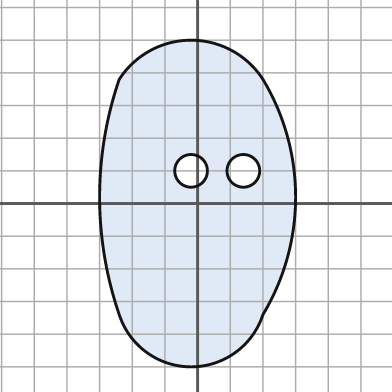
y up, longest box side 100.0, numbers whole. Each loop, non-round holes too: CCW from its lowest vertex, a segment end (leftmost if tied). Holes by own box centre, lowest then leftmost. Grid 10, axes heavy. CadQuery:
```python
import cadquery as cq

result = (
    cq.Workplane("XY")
    .moveTo(-24.0, -34.0)
    .threePointArc((-2.0, -50.0), (20.0, -34.0))
    .threePointArc((30.0, 2.0), (20.0, 38.0))
    .threePointArc((-2.0, 50.0), (-24.0, 38.0))
    .threePointArc((-30.0, 2.0), (-24.0, -34.0))
    .close()
    .moveTo(-2.0, 10.0)
    .circle(5.0)
    .moveTo(14.0, 10.0)
    .circle(5.0)
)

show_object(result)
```